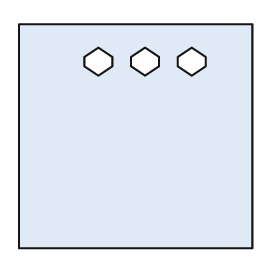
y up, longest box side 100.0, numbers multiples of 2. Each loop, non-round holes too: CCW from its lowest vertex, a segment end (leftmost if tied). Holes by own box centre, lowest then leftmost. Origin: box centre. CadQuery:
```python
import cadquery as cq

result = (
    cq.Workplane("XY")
    .moveTo(-50.0, -48.0)
    .lineTo(50.0, -48.0)
    .lineTo(50.0, 48.0)
    .lineTo(-50.0, 48.0)
    .close()
    .moveTo(-16.0, 26.0)
    .lineTo(-10.0, 30.0)
    .lineTo(-10.0, 34.0)
    .lineTo(-16.0, 38.0)
    .lineTo(-22.0, 34.0)
    .lineTo(-22.0, 30.0)
    .close()
    .moveTo(4.0, 26.0)
    .lineTo(10.0, 30.0)
    .lineTo(10.0, 34.0)
    .lineTo(4.0, 38.0)
    .lineTo(-2.0, 34.0)
    .lineTo(-2.0, 30.0)
    .close()
    .moveTo(24.0, 26.0)
    .lineTo(30.0, 30.0)
    .lineTo(30.0, 34.0)
    .lineTo(24.0, 38.0)
    .lineTo(18.0, 34.0)
    .lineTo(18.0, 30.0)
    .close()
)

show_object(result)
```